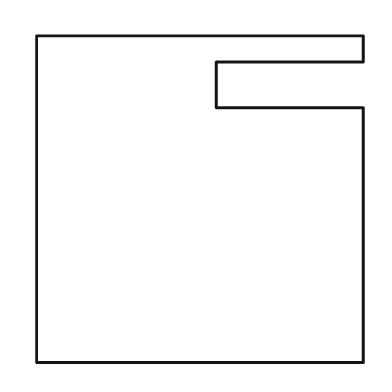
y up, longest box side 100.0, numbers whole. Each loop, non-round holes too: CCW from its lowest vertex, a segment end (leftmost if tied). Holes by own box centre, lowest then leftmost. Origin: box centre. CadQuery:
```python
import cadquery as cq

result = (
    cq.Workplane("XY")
    .moveTo(-50.0, -50.0)
    .lineTo(50.0, -50.0)
    .lineTo(50.0, 28.0)
    .lineTo(5.0, 28.0)
    .lineTo(5.0, 42.0)
    .lineTo(50.0, 42.0)
    .lineTo(50.0, 50.0)
    .lineTo(-50.0, 50.0)
    .close()
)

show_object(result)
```